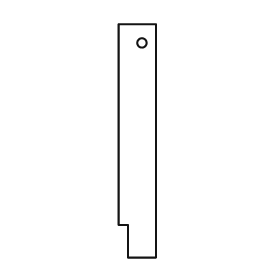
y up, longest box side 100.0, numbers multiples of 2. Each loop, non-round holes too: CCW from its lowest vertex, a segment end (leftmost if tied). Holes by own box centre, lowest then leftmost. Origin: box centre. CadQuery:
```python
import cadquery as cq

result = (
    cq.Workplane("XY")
    .moveTo(-4.0, -50.0)
    .lineTo(8.0, -50.0)
    .lineTo(8.0, 50.0)
    .lineTo(-8.0, 50.0)
    .lineTo(-8.0, -36.0)
    .lineTo(-4.0, -36.0)
    .close()
    .moveTo(2.0, 42.0)
    .circle(2.0)
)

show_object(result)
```